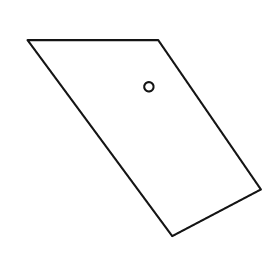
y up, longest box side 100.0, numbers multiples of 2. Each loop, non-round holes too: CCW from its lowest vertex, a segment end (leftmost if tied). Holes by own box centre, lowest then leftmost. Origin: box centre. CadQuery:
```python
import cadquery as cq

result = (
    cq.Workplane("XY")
    .moveTo(12.0, -42.0)
    .lineTo(50.0, -22.0)
    .lineTo(6.0, 42.0)
    .lineTo(-50.0, 42.0)
    .close()
    .moveTo(2.0, 22.0)
    .circle(2.0)
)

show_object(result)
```